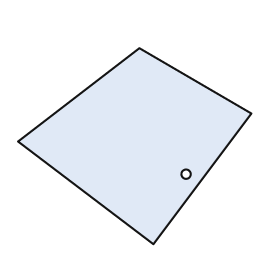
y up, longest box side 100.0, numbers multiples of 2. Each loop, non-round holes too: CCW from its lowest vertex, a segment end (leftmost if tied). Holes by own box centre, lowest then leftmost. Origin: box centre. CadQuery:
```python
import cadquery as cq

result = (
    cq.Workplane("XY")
    .moveTo(8.0, -42.0)
    .lineTo(50.0, 14.0)
    .lineTo(2.0, 42.0)
    .lineTo(-50.0, 2.0)
    .close()
    .moveTo(22.0, -12.0)
    .circle(2.0)
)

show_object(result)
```